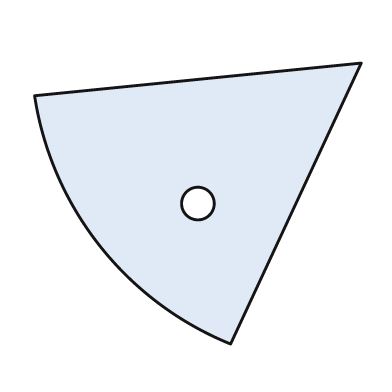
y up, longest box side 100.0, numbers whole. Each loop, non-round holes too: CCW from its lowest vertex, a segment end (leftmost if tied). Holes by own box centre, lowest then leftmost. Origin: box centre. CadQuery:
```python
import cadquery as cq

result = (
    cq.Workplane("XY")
    .moveTo(10.0, -43.0)
    .lineTo(50.0, 43.0)
    .lineTo(-50.0, 33.0)
    .threePointArc((-30.0, -13.0), (10.0, -43.0))
    .close()
    .moveTo(0.0, 0.0)
    .circle(5.0)
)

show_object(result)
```